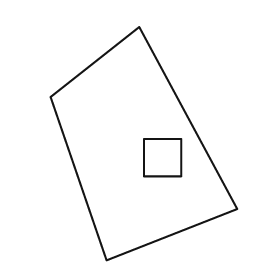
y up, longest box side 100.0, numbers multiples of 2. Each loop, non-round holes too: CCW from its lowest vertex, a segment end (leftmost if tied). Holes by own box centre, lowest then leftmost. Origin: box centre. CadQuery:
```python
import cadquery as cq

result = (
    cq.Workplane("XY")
    .moveTo(-16.0, -50.0)
    .lineTo(40.0, -28.0)
    .lineTo(-2.0, 50.0)
    .lineTo(-40.0, 20.0)
    .close()
    .moveTo(0.0, -14.0)
    .lineTo(16.0, -14.0)
    .lineTo(16.0, 2.0)
    .lineTo(0.0, 2.0)
    .close()
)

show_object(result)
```